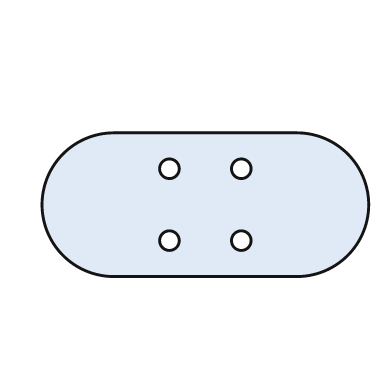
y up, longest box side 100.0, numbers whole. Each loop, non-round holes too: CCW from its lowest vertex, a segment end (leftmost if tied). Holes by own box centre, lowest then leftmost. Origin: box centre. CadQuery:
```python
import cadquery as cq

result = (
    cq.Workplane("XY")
    .moveTo(-28.0, -22.0)
    .lineTo(28.0, -22.0)
    .threePointArc((50.0, 0.0), (28.0, 22.0))
    .lineTo(-28.0, 22.0)
    .threePointArc((-50.0, 0.0), (-28.0, -22.0))
    .close()
    .moveTo(-11.0, -11.0)
    .circle(3.0)
    .moveTo(11.0, -11.0)
    .circle(3.0)
    .moveTo(-11.0, 11.0)
    .circle(3.0)
    .moveTo(11.0, 11.0)
    .circle(3.0)
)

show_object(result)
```